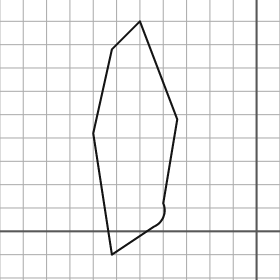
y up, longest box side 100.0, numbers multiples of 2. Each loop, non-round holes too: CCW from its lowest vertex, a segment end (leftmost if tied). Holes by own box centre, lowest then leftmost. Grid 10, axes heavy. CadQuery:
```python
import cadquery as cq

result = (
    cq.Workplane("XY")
    .moveTo(-62.0, -10.0)
    .lineTo(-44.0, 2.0)
    .threePointArc((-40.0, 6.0), (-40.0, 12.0))
    .lineTo(-34.0, 48.0)
    .lineTo(-50.0, 90.0)
    .lineTo(-62.0, 78.0)
    .lineTo(-70.0, 42.0)
    .close()
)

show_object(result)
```